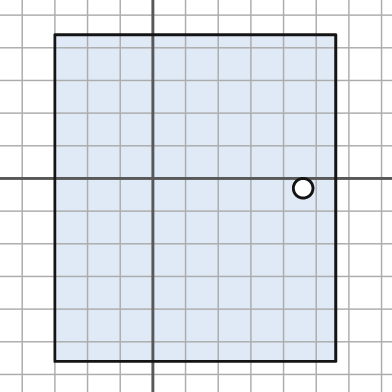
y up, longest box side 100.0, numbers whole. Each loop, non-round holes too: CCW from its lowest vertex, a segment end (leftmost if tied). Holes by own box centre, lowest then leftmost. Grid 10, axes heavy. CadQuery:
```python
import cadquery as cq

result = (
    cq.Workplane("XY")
    .moveTo(-30.0, -56.0)
    .lineTo(56.0, -56.0)
    .lineTo(56.0, 44.0)
    .lineTo(-30.0, 44.0)
    .close()
    .moveTo(46.0, -3.0)
    .circle(3.0)
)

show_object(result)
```